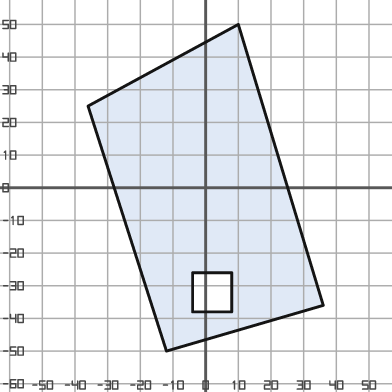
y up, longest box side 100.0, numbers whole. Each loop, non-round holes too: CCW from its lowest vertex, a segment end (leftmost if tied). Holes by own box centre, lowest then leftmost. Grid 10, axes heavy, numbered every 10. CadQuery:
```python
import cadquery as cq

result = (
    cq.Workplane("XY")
    .moveTo(-12.0, -50.0)
    .lineTo(36.0, -36.0)
    .lineTo(10.0, 50.0)
    .lineTo(-36.0, 25.0)
    .close()
    .moveTo(-4.0, -38.0)
    .lineTo(8.0, -38.0)
    .lineTo(8.0, -26.0)
    .lineTo(-4.0, -26.0)
    .close()
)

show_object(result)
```